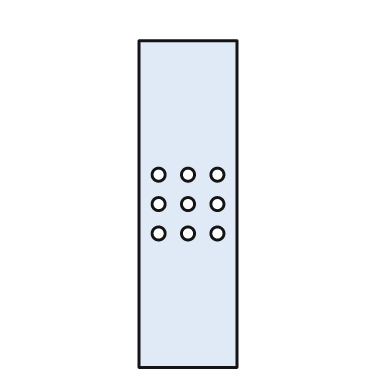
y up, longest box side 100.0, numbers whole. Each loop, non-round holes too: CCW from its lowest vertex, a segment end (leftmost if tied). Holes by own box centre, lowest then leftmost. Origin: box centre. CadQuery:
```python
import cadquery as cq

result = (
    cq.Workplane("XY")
    .moveTo(-15.0, -50.0)
    .lineTo(15.0, -50.0)
    .lineTo(15.0, 50.0)
    .lineTo(-15.0, 50.0)
    .close()
    .moveTo(-9.0, -9.0)
    .circle(2.0)
    .moveTo(0.0, -9.0)
    .circle(2.0)
    .moveTo(9.0, -9.0)
    .circle(2.0)
    .moveTo(-9.0, 0.0)
    .circle(2.0)
    .moveTo(0.0, 0.0)
    .circle(2.0)
    .moveTo(9.0, 0.0)
    .circle(2.0)
    .moveTo(-9.0, 9.0)
    .circle(2.0)
    .moveTo(0.0, 9.0)
    .circle(2.0)
    .moveTo(9.0, 9.0)
    .circle(2.0)
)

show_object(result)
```